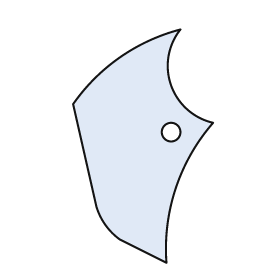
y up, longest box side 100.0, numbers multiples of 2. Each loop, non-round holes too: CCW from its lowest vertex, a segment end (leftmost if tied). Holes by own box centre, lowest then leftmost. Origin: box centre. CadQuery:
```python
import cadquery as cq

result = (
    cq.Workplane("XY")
    .moveTo(10.0, -50.0)
    .threePointArc((14.0, -18.0), (30.0, 10.0))
    .threePointArc((12.0, 26.0), (16.0, 50.0))
    .threePointArc((-10.0, 38.0), (-30.0, 18.0))
    .lineTo(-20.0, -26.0)
    .threePointArc((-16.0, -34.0), (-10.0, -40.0))
    .close()
    .moveTo(12.0, 6.0)
    .circle(4.0)
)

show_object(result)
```